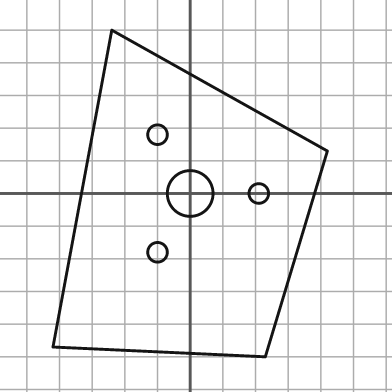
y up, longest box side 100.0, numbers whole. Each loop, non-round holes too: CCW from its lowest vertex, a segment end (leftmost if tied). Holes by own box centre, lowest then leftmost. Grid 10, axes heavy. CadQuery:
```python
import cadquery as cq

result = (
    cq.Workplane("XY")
    .moveTo(23.0, -50.0)
    .lineTo(42.0, 13.0)
    .lineTo(-24.0, 50.0)
    .lineTo(-42.0, -47.0)
    .close()
    .moveTo(-10.0, -18.0)
    .circle(3.0)
    .moveTo(0.0, 0.0)
    .circle(7.0)
    .moveTo(21.0, 0.0)
    .circle(3.0)
    .moveTo(-10.0, 18.0)
    .circle(3.0)
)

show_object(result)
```